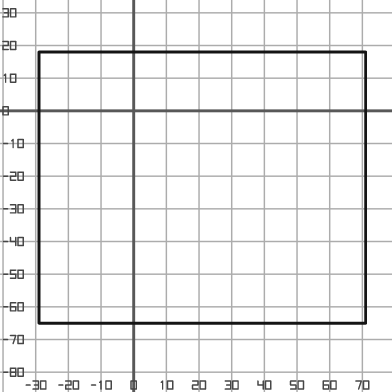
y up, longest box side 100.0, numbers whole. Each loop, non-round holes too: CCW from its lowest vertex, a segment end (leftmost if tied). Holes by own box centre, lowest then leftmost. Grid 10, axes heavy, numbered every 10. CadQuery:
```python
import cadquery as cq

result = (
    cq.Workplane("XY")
    .moveTo(-29.0, -65.0)
    .lineTo(71.0, -65.0)
    .lineTo(71.0, 18.0)
    .lineTo(-29.0, 18.0)
    .close()
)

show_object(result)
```